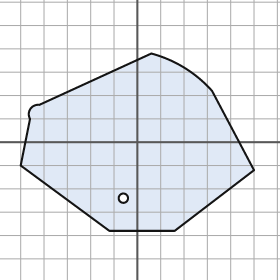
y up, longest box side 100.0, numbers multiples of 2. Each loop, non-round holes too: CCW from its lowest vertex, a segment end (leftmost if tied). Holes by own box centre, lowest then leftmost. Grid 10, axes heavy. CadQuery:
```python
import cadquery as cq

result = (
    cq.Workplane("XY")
    .moveTo(-12.0, -38.0)
    .lineTo(16.0, -38.0)
    .lineTo(50.0, -12.0)
    .lineTo(32.0, 22.0)
    .threePointArc((20.0, 32.0), (6.0, 38.0))
    .lineTo(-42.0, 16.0)
    .threePointArc((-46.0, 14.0), (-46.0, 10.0))
    .lineTo(-50.0, -10.0)
    .close()
    .moveTo(-6.0, -24.0)
    .circle(2.0)
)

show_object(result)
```